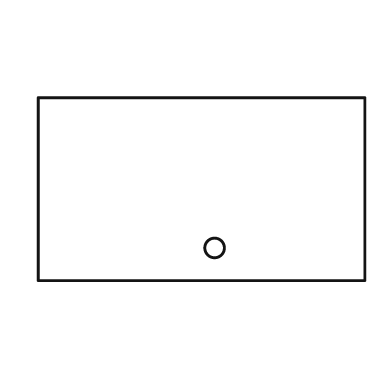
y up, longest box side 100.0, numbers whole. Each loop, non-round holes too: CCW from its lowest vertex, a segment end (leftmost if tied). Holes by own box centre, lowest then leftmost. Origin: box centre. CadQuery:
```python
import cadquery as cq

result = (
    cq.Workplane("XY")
    .moveTo(-50.0, -28.0)
    .lineTo(50.0, -28.0)
    .lineTo(50.0, 28.0)
    .lineTo(-50.0, 28.0)
    .close()
    .moveTo(4.0, -18.0)
    .circle(3.0)
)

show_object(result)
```